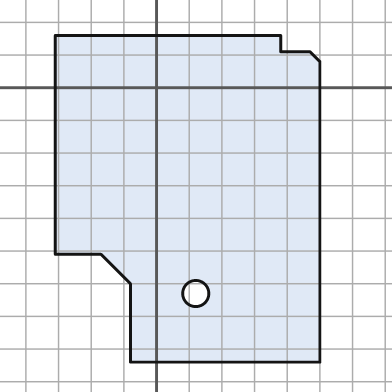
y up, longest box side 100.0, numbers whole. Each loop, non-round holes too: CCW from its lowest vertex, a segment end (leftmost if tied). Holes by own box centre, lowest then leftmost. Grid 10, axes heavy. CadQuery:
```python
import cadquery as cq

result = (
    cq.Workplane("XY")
    .moveTo(-8.0, -84.0)
    .lineTo(50.0, -84.0)
    .lineTo(50.0, 8.0)
    .lineTo(47.0, 11.0)
    .lineTo(38.0, 11.0)
    .lineTo(38.0, 16.0)
    .lineTo(-31.0, 16.0)
    .lineTo(-31.0, -51.0)
    .lineTo(-17.0, -51.0)
    .lineTo(-8.0, -60.0)
    .close()
    .moveTo(12.0, -63.0)
    .circle(4.0)
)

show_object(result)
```